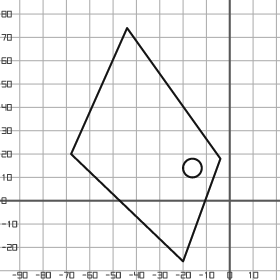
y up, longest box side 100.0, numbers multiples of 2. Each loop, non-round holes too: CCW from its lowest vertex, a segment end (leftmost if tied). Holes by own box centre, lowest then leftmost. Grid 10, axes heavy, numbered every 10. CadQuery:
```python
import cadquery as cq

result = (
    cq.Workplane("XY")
    .moveTo(-20.0, -26.0)
    .lineTo(-4.0, 18.0)
    .lineTo(-44.0, 74.0)
    .lineTo(-68.0, 20.0)
    .close()
    .moveTo(-16.0, 14.0)
    .circle(4.0)
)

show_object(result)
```